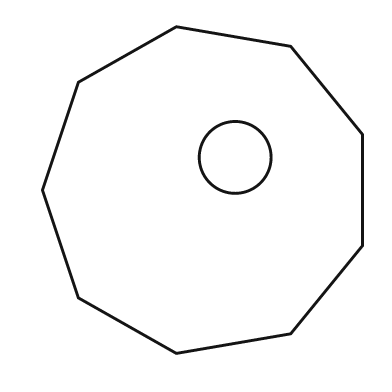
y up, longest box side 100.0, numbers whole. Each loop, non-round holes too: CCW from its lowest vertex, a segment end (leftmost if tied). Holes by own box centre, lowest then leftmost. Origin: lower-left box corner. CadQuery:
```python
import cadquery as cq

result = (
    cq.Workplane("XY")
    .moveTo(41.0, 0.0)
    .lineTo(76.0, 6.0)
    .lineTo(98.0, 33.0)
    .lineTo(98.0, 67.0)
    .lineTo(76.0, 94.0)
    .lineTo(41.0, 100.0)
    .lineTo(11.0, 83.0)
    .lineTo(0.0, 50.0)
    .lineTo(11.0, 17.0)
    .close()
    .moveTo(59.0, 60.0)
    .circle(11.0)
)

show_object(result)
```